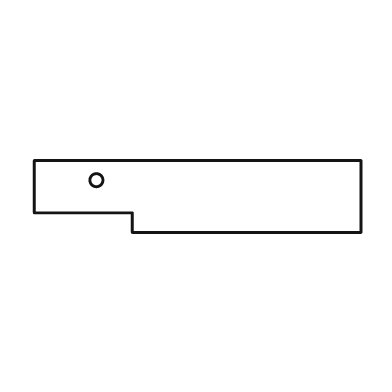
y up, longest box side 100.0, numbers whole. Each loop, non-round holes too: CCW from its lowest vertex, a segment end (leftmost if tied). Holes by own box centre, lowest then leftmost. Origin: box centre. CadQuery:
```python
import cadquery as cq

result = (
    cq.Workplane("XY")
    .moveTo(-20.0, -11.0)
    .lineTo(50.0, -11.0)
    .lineTo(50.0, 11.0)
    .lineTo(-50.0, 11.0)
    .lineTo(-50.0, -5.0)
    .lineTo(-20.0, -5.0)
    .close()
    .moveTo(-31.0, 5.0)
    .circle(2.0)
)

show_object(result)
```